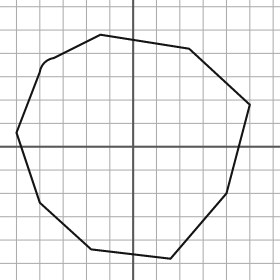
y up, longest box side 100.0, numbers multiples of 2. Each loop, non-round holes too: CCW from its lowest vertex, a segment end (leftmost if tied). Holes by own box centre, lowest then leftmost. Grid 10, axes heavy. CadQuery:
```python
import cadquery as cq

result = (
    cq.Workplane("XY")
    .moveTo(16.0, -48.0)
    .lineTo(40.0, -20.0)
    .lineTo(50.0, 18.0)
    .lineTo(24.0, 42.0)
    .lineTo(-14.0, 48.0)
    .lineTo(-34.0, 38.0)
    .threePointArc((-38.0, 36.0), (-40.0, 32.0))
    .lineTo(-50.0, 6.0)
    .lineTo(-40.0, -24.0)
    .lineTo(-18.0, -44.0)
    .close()
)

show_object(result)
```